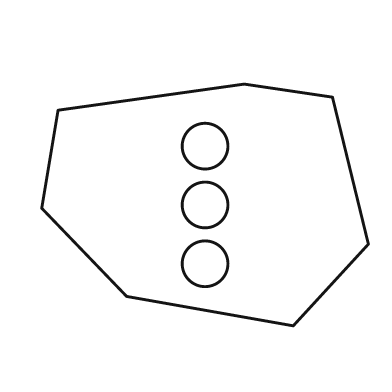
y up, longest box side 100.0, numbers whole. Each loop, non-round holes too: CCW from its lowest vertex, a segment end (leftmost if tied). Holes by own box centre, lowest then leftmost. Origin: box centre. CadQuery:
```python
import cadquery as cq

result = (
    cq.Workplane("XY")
    .moveTo(27.0, -37.0)
    .lineTo(50.0, -12.0)
    .lineTo(39.0, 33.0)
    .lineTo(12.0, 37.0)
    .lineTo(-45.0, 29.0)
    .lineTo(-50.0, -1.0)
    .lineTo(-24.0, -28.0)
    .close()
    .moveTo(0.0, -18.0)
    .circle(7.0)
    .moveTo(0.0, 0.0)
    .circle(7.0)
    .moveTo(0.0, 18.0)
    .circle(7.0)
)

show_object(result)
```